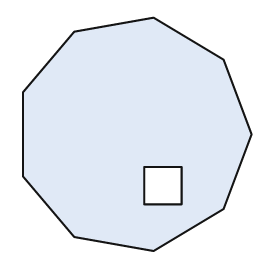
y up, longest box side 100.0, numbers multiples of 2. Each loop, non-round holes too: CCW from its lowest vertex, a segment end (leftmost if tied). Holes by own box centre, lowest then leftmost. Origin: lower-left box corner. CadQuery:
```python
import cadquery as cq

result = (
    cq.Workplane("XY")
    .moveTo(56.0, 0.0)
    .lineTo(86.0, 18.0)
    .lineTo(98.0, 50.0)
    .lineTo(86.0, 82.0)
    .lineTo(56.0, 100.0)
    .lineTo(22.0, 94.0)
    .lineTo(0.0, 68.0)
    .lineTo(0.0, 32.0)
    .lineTo(22.0, 6.0)
    .close()
    .moveTo(52.0, 20.0)
    .lineTo(68.0, 20.0)
    .lineTo(68.0, 36.0)
    .lineTo(52.0, 36.0)
    .close()
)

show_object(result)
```